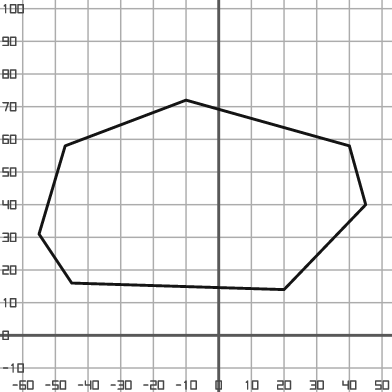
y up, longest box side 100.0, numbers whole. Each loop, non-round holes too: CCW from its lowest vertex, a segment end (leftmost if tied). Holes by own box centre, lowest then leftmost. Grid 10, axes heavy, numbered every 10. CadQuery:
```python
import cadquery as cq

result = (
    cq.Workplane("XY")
    .moveTo(20.0, 14.0)
    .lineTo(45.0, 40.0)
    .lineTo(40.0, 58.0)
    .lineTo(-10.0, 72.0)
    .lineTo(-47.0, 58.0)
    .lineTo(-55.0, 31.0)
    .lineTo(-45.0, 16.0)
    .close()
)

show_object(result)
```